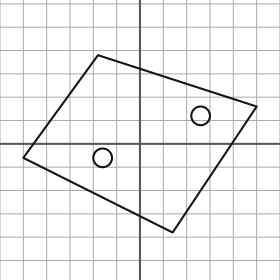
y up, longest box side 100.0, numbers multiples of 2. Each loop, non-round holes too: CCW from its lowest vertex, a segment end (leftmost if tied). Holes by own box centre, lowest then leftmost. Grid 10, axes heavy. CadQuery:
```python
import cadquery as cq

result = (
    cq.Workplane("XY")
    .moveTo(14.0, -38.0)
    .lineTo(50.0, 16.0)
    .lineTo(-18.0, 38.0)
    .lineTo(-50.0, -6.0)
    .close()
    .moveTo(-16.0, -6.0)
    .circle(4.0)
    .moveTo(26.0, 12.0)
    .circle(4.0)
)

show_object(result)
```